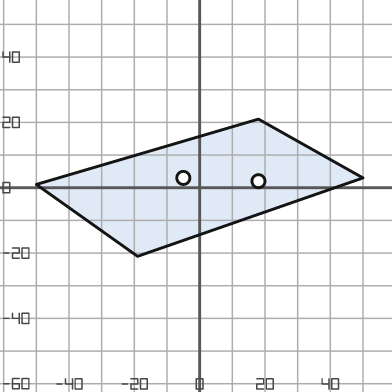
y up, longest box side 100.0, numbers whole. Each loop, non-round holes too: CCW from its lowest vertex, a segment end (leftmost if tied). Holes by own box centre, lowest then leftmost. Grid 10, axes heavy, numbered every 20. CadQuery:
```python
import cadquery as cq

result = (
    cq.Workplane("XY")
    .moveTo(-19.0, -21.0)
    .lineTo(50.0, 3.0)
    .lineTo(18.0, 21.0)
    .lineTo(-50.0, 1.0)
    .close()
    .moveTo(18.0, 2.0)
    .circle(2.0)
    .moveTo(-5.0, 3.0)
    .circle(2.0)
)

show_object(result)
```